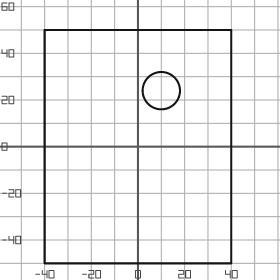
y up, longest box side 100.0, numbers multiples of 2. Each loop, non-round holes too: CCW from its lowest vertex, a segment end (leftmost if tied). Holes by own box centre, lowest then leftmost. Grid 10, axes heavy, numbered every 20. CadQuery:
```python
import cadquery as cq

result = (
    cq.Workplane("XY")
    .moveTo(-40.0, -50.0)
    .lineTo(40.0, -50.0)
    .lineTo(40.0, 50.0)
    .lineTo(-40.0, 50.0)
    .close()
    .moveTo(10.0, 24.0)
    .circle(8.0)
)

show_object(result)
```